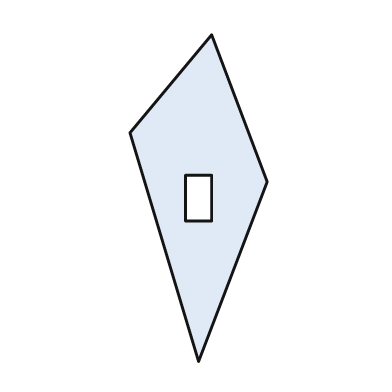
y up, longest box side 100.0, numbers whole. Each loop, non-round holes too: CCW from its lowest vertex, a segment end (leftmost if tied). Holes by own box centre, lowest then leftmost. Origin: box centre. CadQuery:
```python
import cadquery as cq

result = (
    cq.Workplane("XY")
    .moveTo(0.0, -50.0)
    .lineTo(21.0, 5.0)
    .lineTo(4.0, 50.0)
    .lineTo(-21.0, 20.0)
    .close()
    .moveTo(-4.0, -7.0)
    .lineTo(4.0, -7.0)
    .lineTo(4.0, 7.0)
    .lineTo(-4.0, 7.0)
    .close()
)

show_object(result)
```